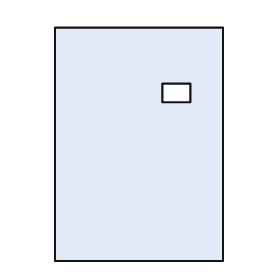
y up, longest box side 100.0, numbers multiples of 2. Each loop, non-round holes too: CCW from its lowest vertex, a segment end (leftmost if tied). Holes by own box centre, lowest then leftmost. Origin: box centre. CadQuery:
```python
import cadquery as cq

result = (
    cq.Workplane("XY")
    .moveTo(-36.0, -50.0)
    .lineTo(36.0, -50.0)
    .lineTo(36.0, 50.0)
    .lineTo(-36.0, 50.0)
    .close()
    .moveTo(10.0, 18.0)
    .lineTo(22.0, 18.0)
    .lineTo(22.0, 26.0)
    .lineTo(10.0, 26.0)
    .close()
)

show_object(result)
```